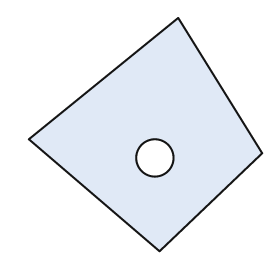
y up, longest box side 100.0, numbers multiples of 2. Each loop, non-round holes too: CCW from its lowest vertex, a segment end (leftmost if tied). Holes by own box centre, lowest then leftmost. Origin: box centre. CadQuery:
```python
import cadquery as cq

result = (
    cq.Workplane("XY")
    .moveTo(6.0, -50.0)
    .lineTo(50.0, -8.0)
    .lineTo(14.0, 50.0)
    .lineTo(-50.0, -2.0)
    .close()
    .moveTo(4.0, -10.0)
    .circle(8.0)
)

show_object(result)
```